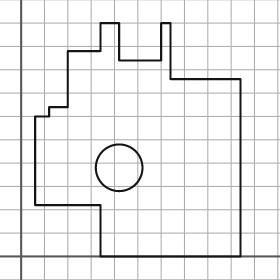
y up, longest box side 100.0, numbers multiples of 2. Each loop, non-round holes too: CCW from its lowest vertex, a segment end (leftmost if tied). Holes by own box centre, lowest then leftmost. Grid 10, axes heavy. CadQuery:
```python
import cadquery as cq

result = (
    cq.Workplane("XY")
    .moveTo(34.0, 0.0)
    .lineTo(94.0, 0.0)
    .lineTo(94.0, 76.0)
    .lineTo(64.0, 76.0)
    .lineTo(64.0, 100.0)
    .lineTo(60.0, 100.0)
    .lineTo(60.0, 84.0)
    .lineTo(42.0, 84.0)
    .lineTo(42.0, 100.0)
    .lineTo(34.0, 100.0)
    .lineTo(34.0, 88.0)
    .lineTo(20.0, 88.0)
    .lineTo(20.0, 64.0)
    .lineTo(12.0, 64.0)
    .lineTo(12.0, 60.0)
    .lineTo(6.0, 60.0)
    .lineTo(6.0, 22.0)
    .lineTo(34.0, 22.0)
    .close()
    .moveTo(42.0, 38.0)
    .circle(10.0)
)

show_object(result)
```